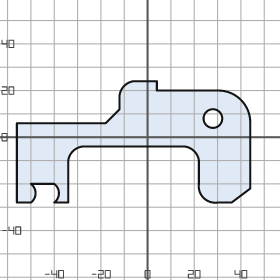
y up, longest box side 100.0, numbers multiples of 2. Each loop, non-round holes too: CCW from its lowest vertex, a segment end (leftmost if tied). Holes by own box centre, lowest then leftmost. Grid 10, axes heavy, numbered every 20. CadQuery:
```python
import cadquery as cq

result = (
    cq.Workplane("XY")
    .moveTo(-56.0, -28.0)
    .lineTo(-50.0, -28.0)
    .threePointArc((-48.0, -24.0), (-50.0, -20.0))
    .lineTo(-40.0, -20.0)
    .threePointArc((-38.0, -24.0), (-40.0, -28.0))
    .lineTo(-34.0, -28.0)
    .lineTo(-34.0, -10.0)
    .threePointArc((-32.0, -6.0), (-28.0, -4.0))
    .lineTo(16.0, -4.0)
    .threePointArc((20.0, -6.0), (22.0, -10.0))
    .lineTo(22.0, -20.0)
    .threePointArc((24.0, -26.0), (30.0, -28.0))
    .lineTo(36.0, -28.0)
    .lineTo(44.0, -22.0)
    .lineTo(44.0, 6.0)
    .threePointArc((40.0, 16.0), (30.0, 20.0))
    .lineTo(4.0, 20.0)
    .lineTo(4.0, 24.0)
    .lineTo(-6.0, 24.0)
    .threePointArc((-10.0, 22.0), (-12.0, 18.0))
    .lineTo(-12.0, 12.0)
    .lineTo(-18.0, 6.0)
    .lineTo(-56.0, 6.0)
    .close()
    .moveTo(28.0, 8.0)
    .circle(4.0)
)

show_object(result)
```